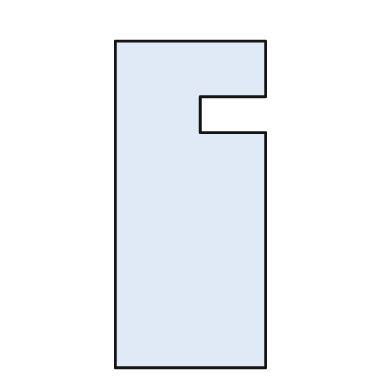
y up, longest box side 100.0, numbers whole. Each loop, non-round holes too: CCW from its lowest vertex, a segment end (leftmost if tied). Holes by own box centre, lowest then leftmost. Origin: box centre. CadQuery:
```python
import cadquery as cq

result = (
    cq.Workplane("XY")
    .moveTo(-23.0, -50.0)
    .lineTo(23.0, -50.0)
    .lineTo(23.0, 22.0)
    .lineTo(3.0, 22.0)
    .lineTo(3.0, 33.0)
    .lineTo(23.0, 33.0)
    .lineTo(23.0, 50.0)
    .lineTo(-23.0, 50.0)
    .close()
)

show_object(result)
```